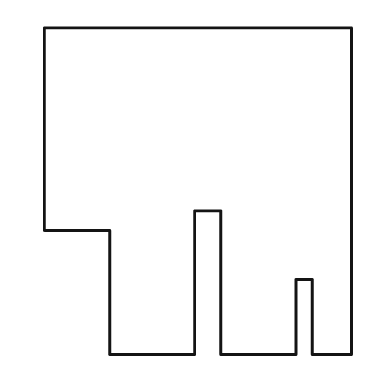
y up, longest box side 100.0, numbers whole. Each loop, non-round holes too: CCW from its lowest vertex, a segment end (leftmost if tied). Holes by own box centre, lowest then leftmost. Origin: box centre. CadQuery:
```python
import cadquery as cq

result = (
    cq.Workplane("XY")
    .moveTo(-27.0, -50.0)
    .lineTo(-1.0, -50.0)
    .lineTo(-1.0, -6.0)
    .lineTo(7.0, -6.0)
    .lineTo(7.0, -50.0)
    .lineTo(30.0, -50.0)
    .lineTo(30.0, -27.0)
    .lineTo(35.0, -27.0)
    .lineTo(35.0, -50.0)
    .lineTo(47.0, -50.0)
    .lineTo(47.0, 50.0)
    .lineTo(-47.0, 50.0)
    .lineTo(-47.0, -12.0)
    .lineTo(-27.0, -12.0)
    .close()
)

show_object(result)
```